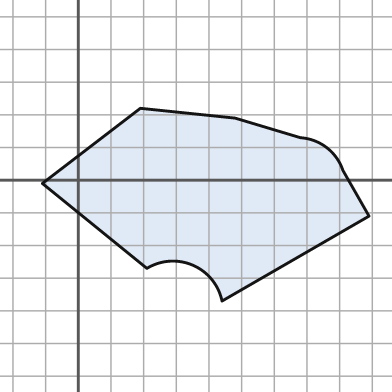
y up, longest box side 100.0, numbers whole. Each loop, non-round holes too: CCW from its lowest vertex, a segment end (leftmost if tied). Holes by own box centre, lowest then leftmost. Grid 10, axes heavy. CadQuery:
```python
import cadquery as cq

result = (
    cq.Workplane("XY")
    .moveTo(44.0, -37.0)
    .lineTo(89.0, -11.0)
    .lineTo(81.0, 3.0)
    .threePointArc((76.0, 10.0), (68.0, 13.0))
    .lineTo(48.0, 19.0)
    .lineTo(19.0, 22.0)
    .lineTo(-11.0, -1.0)
    .lineTo(21.0, -27.0)
    .threePointArc((35.0, -26.0), (44.0, -37.0))
    .close()
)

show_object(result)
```